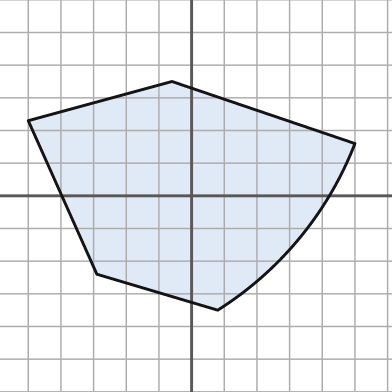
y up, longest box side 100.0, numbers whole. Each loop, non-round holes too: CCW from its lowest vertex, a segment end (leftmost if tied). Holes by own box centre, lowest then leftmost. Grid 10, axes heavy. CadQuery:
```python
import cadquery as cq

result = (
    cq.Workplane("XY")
    .moveTo(8.0, -35.0)
    .threePointArc((33.0, -13.0), (50.0, 16.0))
    .lineTo(-6.0, 35.0)
    .lineTo(-50.0, 23.0)
    .lineTo(-29.0, -24.0)
    .close()
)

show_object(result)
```